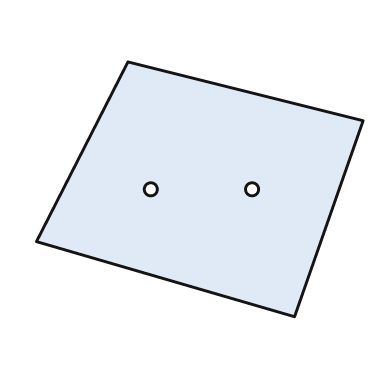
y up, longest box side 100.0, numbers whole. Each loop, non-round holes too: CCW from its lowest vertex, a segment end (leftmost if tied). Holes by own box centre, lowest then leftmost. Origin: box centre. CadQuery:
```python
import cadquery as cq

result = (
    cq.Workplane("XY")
    .moveTo(29.0, -39.0)
    .lineTo(50.0, 21.0)
    .lineTo(-22.0, 39.0)
    .lineTo(-50.0, -16.0)
    .close()
    .moveTo(-15.0, 0.0)
    .circle(2.0)
    .moveTo(16.0, 0.0)
    .circle(2.0)
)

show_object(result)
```